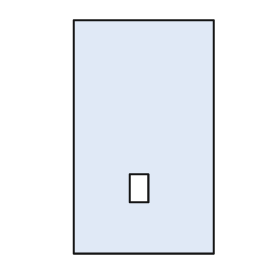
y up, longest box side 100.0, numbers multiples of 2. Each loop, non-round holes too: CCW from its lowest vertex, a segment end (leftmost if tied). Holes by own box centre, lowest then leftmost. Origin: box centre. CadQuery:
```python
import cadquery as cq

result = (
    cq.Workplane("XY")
    .moveTo(-30.0, -50.0)
    .lineTo(30.0, -50.0)
    .lineTo(30.0, 50.0)
    .lineTo(-30.0, 50.0)
    .close()
    .moveTo(-6.0, -28.0)
    .lineTo(2.0, -28.0)
    .lineTo(2.0, -16.0)
    .lineTo(-6.0, -16.0)
    .close()
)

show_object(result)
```